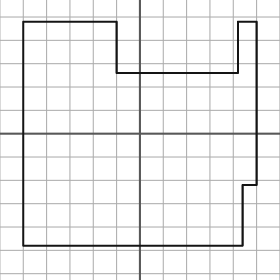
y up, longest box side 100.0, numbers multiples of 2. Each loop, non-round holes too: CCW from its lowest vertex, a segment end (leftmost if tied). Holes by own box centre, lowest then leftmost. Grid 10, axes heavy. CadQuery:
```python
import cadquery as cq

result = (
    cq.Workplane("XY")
    .moveTo(-50.0, -48.0)
    .lineTo(44.0, -48.0)
    .lineTo(44.0, -22.0)
    .lineTo(50.0, -22.0)
    .lineTo(50.0, 48.0)
    .lineTo(42.0, 48.0)
    .lineTo(42.0, 26.0)
    .lineTo(-10.0, 26.0)
    .lineTo(-10.0, 48.0)
    .lineTo(-50.0, 48.0)
    .close()
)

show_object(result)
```